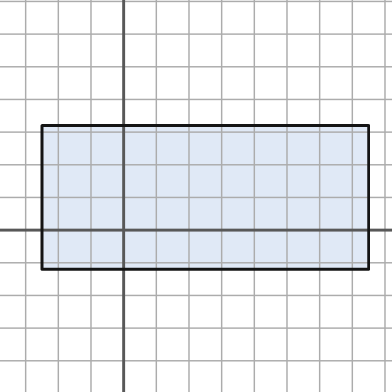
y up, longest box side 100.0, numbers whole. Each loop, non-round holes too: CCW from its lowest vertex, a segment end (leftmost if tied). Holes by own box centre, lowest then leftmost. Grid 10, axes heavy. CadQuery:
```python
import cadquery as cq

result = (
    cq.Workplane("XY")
    .moveTo(-25.0, -12.0)
    .lineTo(75.0, -12.0)
    .lineTo(75.0, 32.0)
    .lineTo(-25.0, 32.0)
    .close()
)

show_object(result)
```